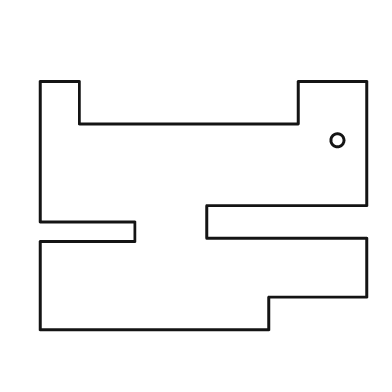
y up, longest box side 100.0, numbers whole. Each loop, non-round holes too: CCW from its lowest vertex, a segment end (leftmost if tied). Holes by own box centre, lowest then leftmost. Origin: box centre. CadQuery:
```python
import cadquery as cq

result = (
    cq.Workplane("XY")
    .moveTo(-50.0, -38.0)
    .lineTo(20.0, -38.0)
    .lineTo(20.0, -28.0)
    .lineTo(50.0, -28.0)
    .lineTo(50.0, -10.0)
    .lineTo(1.0, -10.0)
    .lineTo(1.0, 0.0)
    .lineTo(50.0, 0.0)
    .lineTo(50.0, 38.0)
    .lineTo(29.0, 38.0)
    .lineTo(29.0, 25.0)
    .lineTo(-38.0, 25.0)
    .lineTo(-38.0, 38.0)
    .lineTo(-50.0, 38.0)
    .lineTo(-50.0, -5.0)
    .lineTo(-21.0, -5.0)
    .lineTo(-21.0, -11.0)
    .lineTo(-50.0, -11.0)
    .close()
    .moveTo(41.0, 20.0)
    .circle(2.0)
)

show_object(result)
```